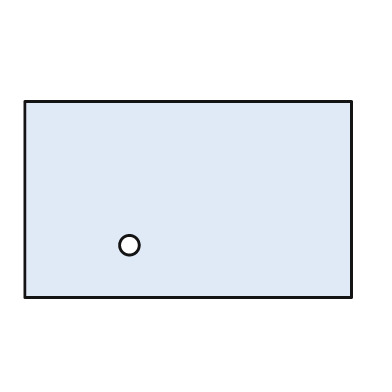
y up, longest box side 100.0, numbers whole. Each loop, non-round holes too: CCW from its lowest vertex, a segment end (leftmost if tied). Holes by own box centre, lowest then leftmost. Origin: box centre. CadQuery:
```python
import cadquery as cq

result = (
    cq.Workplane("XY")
    .moveTo(-50.0, -30.0)
    .lineTo(50.0, -30.0)
    .lineTo(50.0, 30.0)
    .lineTo(-50.0, 30.0)
    .close()
    .moveTo(-18.0, -14.0)
    .circle(3.0)
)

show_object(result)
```